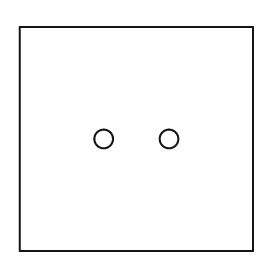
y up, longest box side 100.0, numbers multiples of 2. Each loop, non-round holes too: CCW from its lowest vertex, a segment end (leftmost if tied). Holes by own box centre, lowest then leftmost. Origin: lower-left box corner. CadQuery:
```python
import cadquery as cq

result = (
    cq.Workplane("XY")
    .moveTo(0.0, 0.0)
    .lineTo(100.0, 0.0)
    .lineTo(100.0, 96.0)
    .lineTo(0.0, 96.0)
    .close()
    .moveTo(36.0, 48.0)
    .circle(4.0)
    .moveTo(64.0, 48.0)
    .circle(4.0)
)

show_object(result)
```